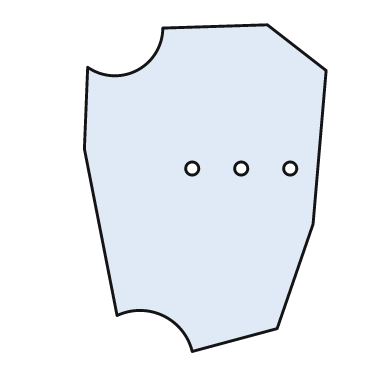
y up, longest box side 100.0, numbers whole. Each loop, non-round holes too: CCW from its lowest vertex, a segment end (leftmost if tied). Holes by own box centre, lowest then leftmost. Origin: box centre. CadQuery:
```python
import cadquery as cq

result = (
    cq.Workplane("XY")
    .moveTo(-4.0, -50.0)
    .lineTo(22.0, -43.0)
    .lineTo(33.0, -11.0)
    .lineTo(37.0, 36.0)
    .lineTo(19.0, 50.0)
    .lineTo(-13.0, 49.0)
    .threePointArc((-21.0, 36.0), (-36.0, 37.0))
    .lineTo(-37.0, 12.0)
    .lineTo(-27.0, -39.0)
    .threePointArc((-13.0, -39.0), (-4.0, -50.0))
    .close()
    .moveTo(-4.0, 6.0)
    .circle(2.0)
    .moveTo(11.0, 6.0)
    .circle(2.0)
    .moveTo(26.0, 6.0)
    .circle(2.0)
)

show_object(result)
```